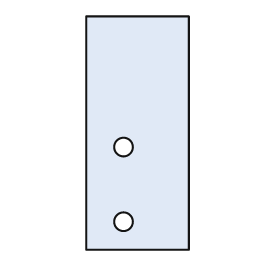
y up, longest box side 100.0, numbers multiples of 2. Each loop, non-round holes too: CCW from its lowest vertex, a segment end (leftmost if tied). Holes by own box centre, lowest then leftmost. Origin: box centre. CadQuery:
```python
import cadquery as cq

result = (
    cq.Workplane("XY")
    .moveTo(-22.0, -50.0)
    .lineTo(22.0, -50.0)
    .lineTo(22.0, 50.0)
    .lineTo(-22.0, 50.0)
    .close()
    .moveTo(-6.0, -38.0)
    .circle(4.0)
    .moveTo(-6.0, -6.0)
    .circle(4.0)
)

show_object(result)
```